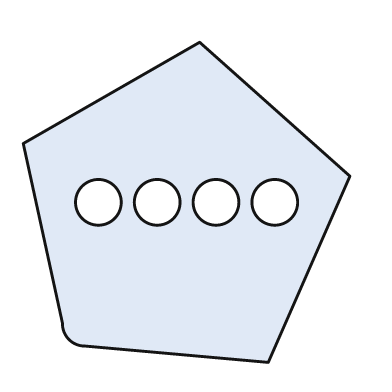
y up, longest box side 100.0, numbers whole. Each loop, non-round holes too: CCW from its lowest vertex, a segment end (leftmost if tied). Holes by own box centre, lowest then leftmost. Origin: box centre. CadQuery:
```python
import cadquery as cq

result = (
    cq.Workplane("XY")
    .moveTo(25.0, -49.0)
    .lineTo(50.0, 8.0)
    .lineTo(4.0, 49.0)
    .lineTo(-50.0, 18.0)
    .lineTo(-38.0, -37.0)
    .threePointArc((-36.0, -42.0), (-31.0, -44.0))
    .close()
    .moveTo(-27.0, 0.0)
    .circle(7.0)
    .moveTo(-9.0, 0.0)
    .circle(7.0)
    .moveTo(9.0, 0.0)
    .circle(7.0)
    .moveTo(27.0, 0.0)
    .circle(7.0)
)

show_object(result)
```